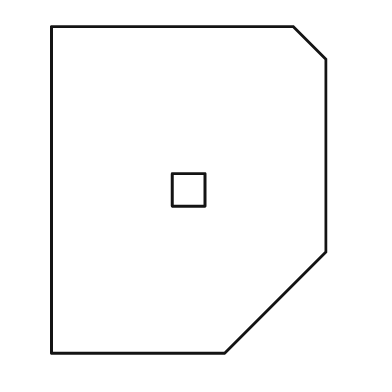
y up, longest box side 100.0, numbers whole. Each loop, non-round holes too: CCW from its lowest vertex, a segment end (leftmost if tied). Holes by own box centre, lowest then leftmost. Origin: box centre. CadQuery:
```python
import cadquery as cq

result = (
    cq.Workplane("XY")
    .moveTo(-42.0, -50.0)
    .lineTo(11.0, -50.0)
    .lineTo(42.0, -19.0)
    .lineTo(42.0, 40.0)
    .lineTo(32.0, 50.0)
    .lineTo(-42.0, 50.0)
    .close()
    .moveTo(-5.0, -5.0)
    .lineTo(5.0, -5.0)
    .lineTo(5.0, 5.0)
    .lineTo(-5.0, 5.0)
    .close()
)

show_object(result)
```